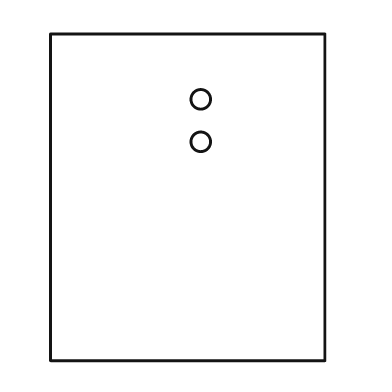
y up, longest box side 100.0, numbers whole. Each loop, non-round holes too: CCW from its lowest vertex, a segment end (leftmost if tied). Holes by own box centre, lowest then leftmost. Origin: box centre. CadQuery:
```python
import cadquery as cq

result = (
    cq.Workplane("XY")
    .moveTo(-42.0, -50.0)
    .lineTo(42.0, -50.0)
    .lineTo(42.0, 50.0)
    .lineTo(-42.0, 50.0)
    .close()
    .moveTo(4.0, 17.0)
    .circle(3.0)
    .moveTo(4.0, 30.0)
    .circle(3.0)
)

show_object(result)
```